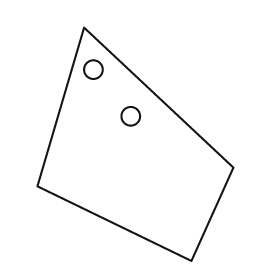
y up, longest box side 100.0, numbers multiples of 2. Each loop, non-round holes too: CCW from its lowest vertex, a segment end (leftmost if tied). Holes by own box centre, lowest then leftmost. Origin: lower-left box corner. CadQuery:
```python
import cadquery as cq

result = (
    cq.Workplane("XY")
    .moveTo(66.0, 0.0)
    .lineTo(84.0, 40.0)
    .lineTo(20.0, 100.0)
    .lineTo(0.0, 32.0)
    .close()
    .moveTo(40.0, 62.0)
    .circle(4.0)
    .moveTo(24.0, 82.0)
    .circle(4.0)
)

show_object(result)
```